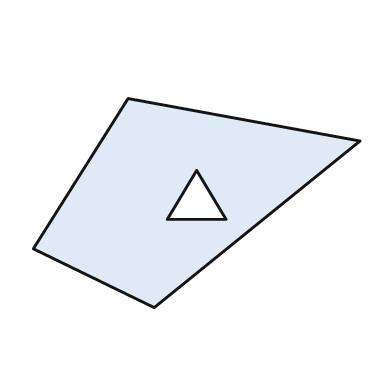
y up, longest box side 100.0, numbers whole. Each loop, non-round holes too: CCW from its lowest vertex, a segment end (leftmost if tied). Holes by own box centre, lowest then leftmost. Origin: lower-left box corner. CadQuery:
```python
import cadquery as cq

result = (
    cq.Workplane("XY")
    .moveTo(37.0, 0.0)
    .lineTo(100.0, 51.0)
    .lineTo(29.0, 64.0)
    .lineTo(0.0, 18.0)
    .close()
    .moveTo(41.0, 27.0)
    .lineTo(59.0, 27.0)
    .lineTo(50.0, 42.0)
    .close()
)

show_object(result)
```